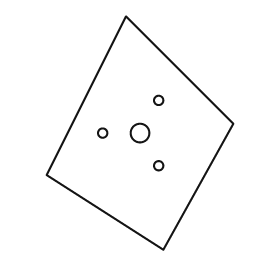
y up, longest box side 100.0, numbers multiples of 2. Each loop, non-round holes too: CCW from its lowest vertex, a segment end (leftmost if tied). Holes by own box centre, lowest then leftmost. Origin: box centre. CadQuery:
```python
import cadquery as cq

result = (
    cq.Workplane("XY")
    .moveTo(10.0, -50.0)
    .lineTo(40.0, 4.0)
    .lineTo(-6.0, 50.0)
    .lineTo(-40.0, -18.0)
    .close()
    .moveTo(8.0, -14.0)
    .circle(2.0)
    .moveTo(-16.0, 0.0)
    .circle(2.0)
    .moveTo(0.0, 0.0)
    .circle(4.0)
    .moveTo(8.0, 14.0)
    .circle(2.0)
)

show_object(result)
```